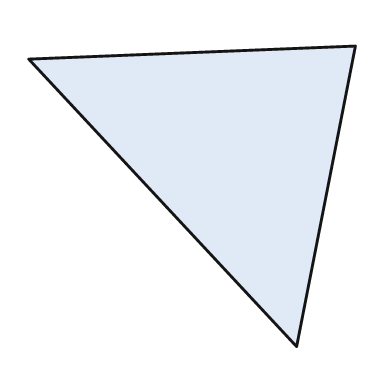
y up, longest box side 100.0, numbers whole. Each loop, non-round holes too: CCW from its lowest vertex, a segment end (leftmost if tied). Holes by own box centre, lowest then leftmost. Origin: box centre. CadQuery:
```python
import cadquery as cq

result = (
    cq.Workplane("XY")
    .moveTo(32.0, -46.0)
    .lineTo(50.0, 46.0)
    .lineTo(-50.0, 42.0)
    .close()
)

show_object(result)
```